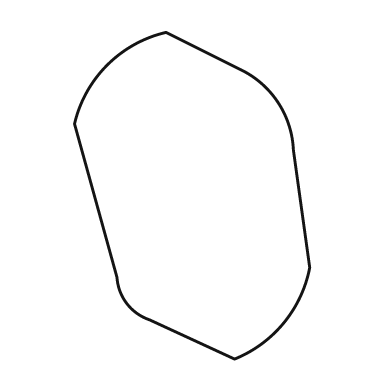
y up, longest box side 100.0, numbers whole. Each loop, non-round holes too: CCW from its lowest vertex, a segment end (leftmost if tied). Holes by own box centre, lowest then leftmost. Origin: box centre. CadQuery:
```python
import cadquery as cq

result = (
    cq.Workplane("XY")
    .moveTo(13.0, -50.0)
    .threePointArc((28.0, -39.0), (36.0, -22.0))
    .lineTo(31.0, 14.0)
    .threePointArc((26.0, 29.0), (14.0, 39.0))
    .lineTo(-8.0, 50.0)
    .threePointArc((-26.0, 40.0), (-36.0, 22.0))
    .lineTo(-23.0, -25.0)
    .threePointArc((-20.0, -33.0), (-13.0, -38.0))
    .close()
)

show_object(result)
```